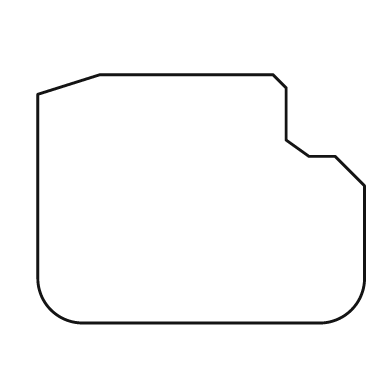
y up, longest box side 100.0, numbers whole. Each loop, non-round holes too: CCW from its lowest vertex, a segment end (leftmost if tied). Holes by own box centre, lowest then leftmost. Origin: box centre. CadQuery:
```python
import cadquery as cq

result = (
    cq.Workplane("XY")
    .moveTo(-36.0, -38.0)
    .lineTo(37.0, -38.0)
    .threePointArc((46.0, -34.0), (50.0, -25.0))
    .lineTo(50.0, 4.0)
    .lineTo(41.0, 13.0)
    .lineTo(33.0, 13.0)
    .lineTo(26.0, 18.0)
    .lineTo(26.0, 34.0)
    .lineTo(22.0, 38.0)
    .lineTo(-31.0, 38.0)
    .lineTo(-50.0, 32.0)
    .lineTo(-50.0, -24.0)
    .threePointArc((-46.0, -34.0), (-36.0, -38.0))
    .close()
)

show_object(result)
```